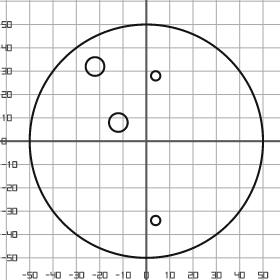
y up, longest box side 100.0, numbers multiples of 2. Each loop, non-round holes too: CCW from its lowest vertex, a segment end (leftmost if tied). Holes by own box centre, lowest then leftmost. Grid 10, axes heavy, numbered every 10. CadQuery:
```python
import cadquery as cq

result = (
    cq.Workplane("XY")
    .moveTo(0.0, 0.0)
    .circle(50.0)
    .moveTo(4.0, -34.0)
    .circle(2.0)
    .moveTo(-12.0, 8.0)
    .circle(4.0)
    .moveTo(4.0, 28.0)
    .circle(2.0)
    .moveTo(-22.0, 32.0)
    .circle(4.0)
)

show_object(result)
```